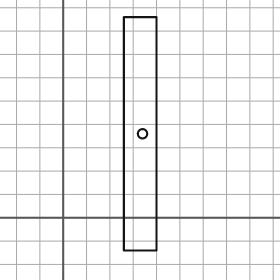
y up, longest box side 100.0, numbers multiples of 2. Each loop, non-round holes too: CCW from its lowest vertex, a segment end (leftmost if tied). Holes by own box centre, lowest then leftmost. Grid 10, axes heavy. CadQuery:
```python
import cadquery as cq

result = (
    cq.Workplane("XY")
    .moveTo(26.0, -14.0)
    .lineTo(40.0, -14.0)
    .lineTo(40.0, 86.0)
    .lineTo(26.0, 86.0)
    .close()
    .moveTo(34.0, 36.0)
    .circle(2.0)
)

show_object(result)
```